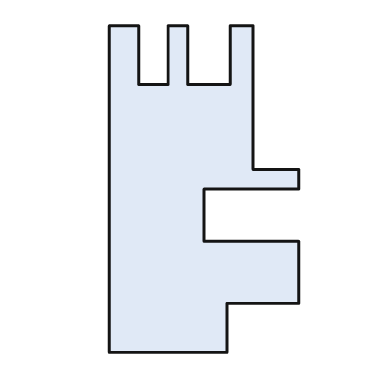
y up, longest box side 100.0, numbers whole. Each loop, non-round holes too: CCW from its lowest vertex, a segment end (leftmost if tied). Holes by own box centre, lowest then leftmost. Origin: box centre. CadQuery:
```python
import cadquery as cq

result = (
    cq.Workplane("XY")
    .moveTo(-29.0, -50.0)
    .lineTo(7.0, -50.0)
    .lineTo(7.0, -35.0)
    .lineTo(29.0, -35.0)
    .lineTo(29.0, -16.0)
    .lineTo(0.0, -16.0)
    .lineTo(0.0, 0.0)
    .lineTo(29.0, 0.0)
    .lineTo(29.0, 6.0)
    .lineTo(15.0, 6.0)
    .lineTo(15.0, 50.0)
    .lineTo(8.0, 50.0)
    .lineTo(8.0, 32.0)
    .lineTo(-5.0, 32.0)
    .lineTo(-5.0, 50.0)
    .lineTo(-11.0, 50.0)
    .lineTo(-11.0, 32.0)
    .lineTo(-20.0, 32.0)
    .lineTo(-20.0, 50.0)
    .lineTo(-29.0, 50.0)
    .close()
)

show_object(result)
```